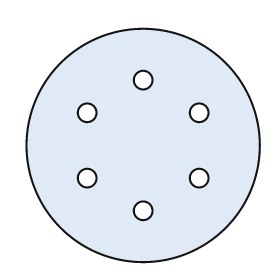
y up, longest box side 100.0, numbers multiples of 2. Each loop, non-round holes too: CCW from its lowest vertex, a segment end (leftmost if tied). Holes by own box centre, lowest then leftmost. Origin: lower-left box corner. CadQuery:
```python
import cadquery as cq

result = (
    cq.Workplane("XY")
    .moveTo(50.0, 50.0)
    .circle(50.0)
    .moveTo(50.0, 22.0)
    .circle(4.0)
    .moveTo(26.0, 36.0)
    .circle(4.0)
    .moveTo(74.0, 36.0)
    .circle(4.0)
    .moveTo(26.0, 64.0)
    .circle(4.0)
    .moveTo(74.0, 64.0)
    .circle(4.0)
    .moveTo(50.0, 78.0)
    .circle(4.0)
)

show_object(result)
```